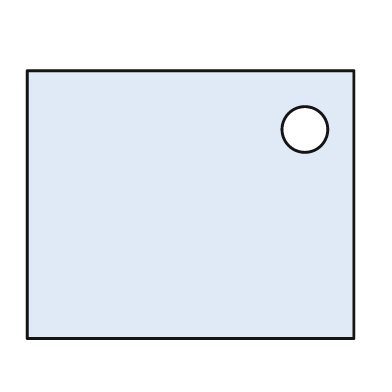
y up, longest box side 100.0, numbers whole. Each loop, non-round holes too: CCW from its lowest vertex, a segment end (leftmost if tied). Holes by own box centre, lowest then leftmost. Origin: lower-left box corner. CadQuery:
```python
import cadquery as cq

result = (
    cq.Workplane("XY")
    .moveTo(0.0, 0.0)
    .lineTo(100.0, 0.0)
    .lineTo(100.0, 82.0)
    .lineTo(0.0, 82.0)
    .close()
    .moveTo(85.0, 64.0)
    .circle(7.0)
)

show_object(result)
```